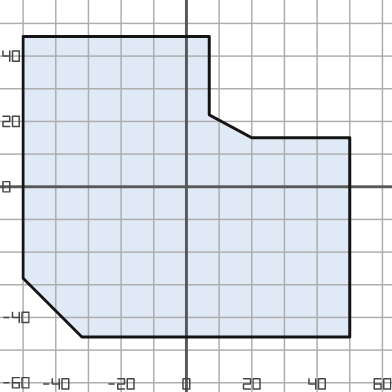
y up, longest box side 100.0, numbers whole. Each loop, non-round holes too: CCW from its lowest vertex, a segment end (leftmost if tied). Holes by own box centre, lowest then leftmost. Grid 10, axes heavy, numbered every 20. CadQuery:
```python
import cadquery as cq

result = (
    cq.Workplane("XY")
    .moveTo(-32.0, -46.0)
    .lineTo(50.0, -46.0)
    .lineTo(50.0, 15.0)
    .lineTo(20.0, 15.0)
    .lineTo(7.0, 22.0)
    .lineTo(7.0, 46.0)
    .lineTo(-50.0, 46.0)
    .lineTo(-50.0, -28.0)
    .close()
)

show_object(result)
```